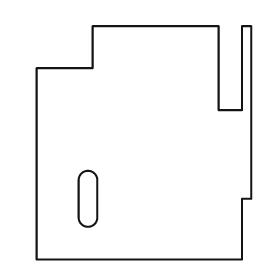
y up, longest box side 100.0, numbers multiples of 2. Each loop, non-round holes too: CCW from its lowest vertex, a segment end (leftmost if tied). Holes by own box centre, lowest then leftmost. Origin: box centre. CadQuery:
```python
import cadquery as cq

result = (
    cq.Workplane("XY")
    .moveTo(-46.0, -50.0)
    .lineTo(42.0, -50.0)
    .lineTo(42.0, -24.0)
    .lineTo(46.0, -24.0)
    .lineTo(46.0, 50.0)
    .lineTo(42.0, 50.0)
    .lineTo(42.0, 14.0)
    .lineTo(32.0, 14.0)
    .lineTo(32.0, 50.0)
    .lineTo(-22.0, 50.0)
    .lineTo(-22.0, 32.0)
    .lineTo(-46.0, 32.0)
    .close()
    .moveTo(-28.0, -32.0)
    .threePointArc((-24.0, -36.0), (-20.0, -32.0))
    .lineTo(-20.0, -16.0)
    .threePointArc((-24.0, -12.0), (-28.0, -16.0))
    .close()
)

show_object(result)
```